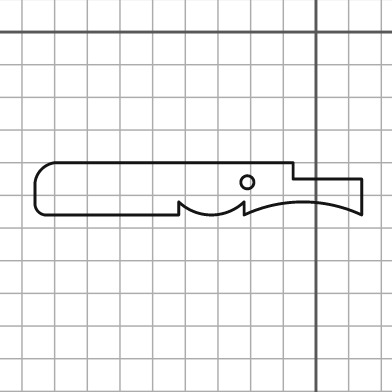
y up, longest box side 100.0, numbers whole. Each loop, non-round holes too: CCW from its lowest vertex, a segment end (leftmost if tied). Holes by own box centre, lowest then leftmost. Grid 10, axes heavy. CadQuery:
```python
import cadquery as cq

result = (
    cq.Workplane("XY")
    .moveTo(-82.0, -56.0)
    .lineTo(-42.0, -56.0)
    .lineTo(-42.0, -52.0)
    .threePointArc((-32.0, -56.0), (-22.0, -52.0))
    .lineTo(-22.0, -56.0)
    .threePointArc((-4.0, -52.0), (14.0, -56.0))
    .lineTo(14.0, -45.0)
    .lineTo(-7.0, -45.0)
    .lineTo(-7.0, -40.0)
    .lineTo(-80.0, -40.0)
    .threePointArc((-84.0, -42.0), (-86.0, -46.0))
    .lineTo(-86.0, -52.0)
    .threePointArc((-85.0, -55.0), (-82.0, -56.0))
    .close()
    .moveTo(-21.0, -46.0)
    .circle(2.0)
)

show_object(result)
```